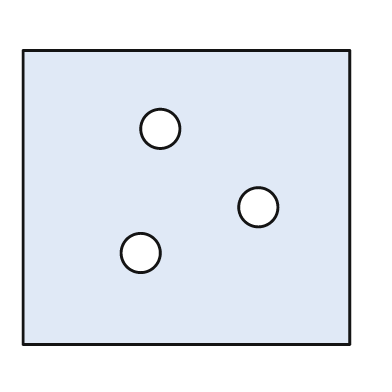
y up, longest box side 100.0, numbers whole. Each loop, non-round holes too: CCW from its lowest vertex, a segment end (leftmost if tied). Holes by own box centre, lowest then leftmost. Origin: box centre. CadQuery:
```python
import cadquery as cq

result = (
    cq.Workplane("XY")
    .moveTo(-50.0, -45.0)
    .lineTo(50.0, -45.0)
    .lineTo(50.0, 45.0)
    .lineTo(-50.0, 45.0)
    .close()
    .moveTo(-14.0, -17.0)
    .circle(6.0)
    .moveTo(22.0, -3.0)
    .circle(6.0)
    .moveTo(-8.0, 21.0)
    .circle(6.0)
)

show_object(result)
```